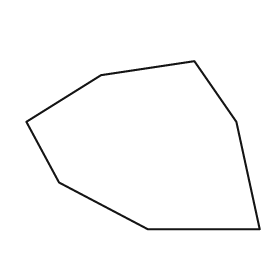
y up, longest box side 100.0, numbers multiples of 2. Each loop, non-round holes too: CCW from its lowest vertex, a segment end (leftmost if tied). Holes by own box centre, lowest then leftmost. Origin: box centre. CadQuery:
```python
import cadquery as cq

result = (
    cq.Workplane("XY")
    .moveTo(2.0, -36.0)
    .lineTo(50.0, -36.0)
    .lineTo(40.0, 10.0)
    .lineTo(22.0, 36.0)
    .lineTo(-18.0, 30.0)
    .lineTo(-50.0, 10.0)
    .lineTo(-36.0, -16.0)
    .close()
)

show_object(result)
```